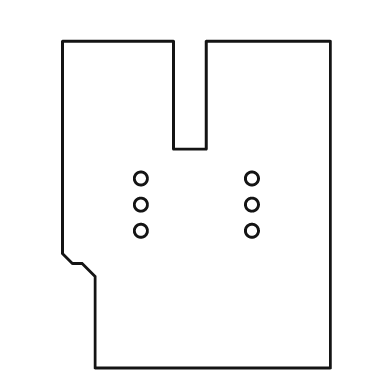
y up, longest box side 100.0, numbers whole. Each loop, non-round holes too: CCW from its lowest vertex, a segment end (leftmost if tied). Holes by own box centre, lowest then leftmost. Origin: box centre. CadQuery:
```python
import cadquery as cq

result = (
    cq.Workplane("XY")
    .moveTo(-31.0, -50.0)
    .lineTo(41.0, -50.0)
    .lineTo(41.0, 50.0)
    .lineTo(3.0, 50.0)
    .lineTo(3.0, 17.0)
    .lineTo(-7.0, 17.0)
    .lineTo(-7.0, 50.0)
    .lineTo(-41.0, 50.0)
    .lineTo(-41.0, -15.0)
    .lineTo(-38.0, -18.0)
    .lineTo(-35.0, -18.0)
    .lineTo(-31.0, -22.0)
    .close()
    .moveTo(-17.0, -8.0)
    .circle(2.0)
    .moveTo(17.0, -8.0)
    .circle(2.0)
    .moveTo(-17.0, 0.0)
    .circle(2.0)
    .moveTo(17.0, 0.0)
    .circle(2.0)
    .moveTo(-17.0, 8.0)
    .circle(2.0)
    .moveTo(17.0, 8.0)
    .circle(2.0)
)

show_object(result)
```